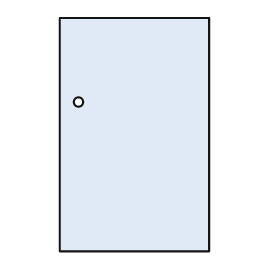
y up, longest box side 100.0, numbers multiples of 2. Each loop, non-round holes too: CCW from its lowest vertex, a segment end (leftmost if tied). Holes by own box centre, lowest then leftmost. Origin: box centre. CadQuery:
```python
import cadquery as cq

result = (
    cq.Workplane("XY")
    .moveTo(-32.0, -50.0)
    .lineTo(32.0, -50.0)
    .lineTo(32.0, 50.0)
    .lineTo(-32.0, 50.0)
    .close()
    .moveTo(-24.0, 14.0)
    .circle(2.0)
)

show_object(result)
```